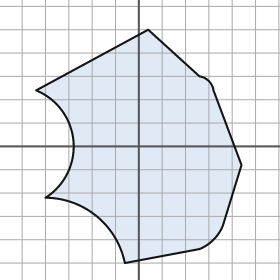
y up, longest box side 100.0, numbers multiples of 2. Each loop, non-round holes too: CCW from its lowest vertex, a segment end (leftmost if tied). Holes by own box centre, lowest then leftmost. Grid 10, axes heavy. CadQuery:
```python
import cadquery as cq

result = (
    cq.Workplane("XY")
    .moveTo(-6.0, -50.0)
    .lineTo(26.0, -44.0)
    .threePointArc((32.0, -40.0), (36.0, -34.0))
    .lineTo(44.0, -8.0)
    .lineTo(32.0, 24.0)
    .threePointArc((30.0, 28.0), (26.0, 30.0))
    .lineTo(4.0, 50.0)
    .lineTo(-44.0, 24.0)
    .threePointArc((-28.0, 2.0), (-40.0, -22.0))
    .threePointArc((-18.0, -30.0), (-6.0, -50.0))
    .close()
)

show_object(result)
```